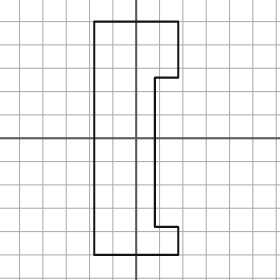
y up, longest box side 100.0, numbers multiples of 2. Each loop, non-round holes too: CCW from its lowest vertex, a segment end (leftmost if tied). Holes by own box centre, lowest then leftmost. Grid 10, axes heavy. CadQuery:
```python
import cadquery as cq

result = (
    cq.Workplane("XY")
    .moveTo(-18.0, -50.0)
    .lineTo(18.0, -50.0)
    .lineTo(18.0, -38.0)
    .lineTo(8.0, -38.0)
    .lineTo(8.0, 26.0)
    .lineTo(18.0, 26.0)
    .lineTo(18.0, 50.0)
    .lineTo(-18.0, 50.0)
    .close()
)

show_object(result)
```